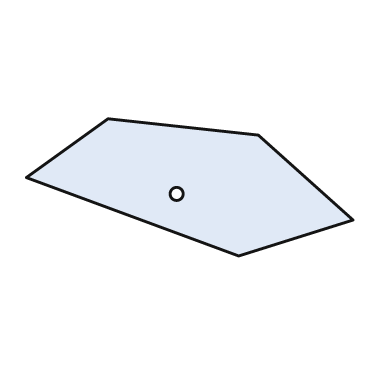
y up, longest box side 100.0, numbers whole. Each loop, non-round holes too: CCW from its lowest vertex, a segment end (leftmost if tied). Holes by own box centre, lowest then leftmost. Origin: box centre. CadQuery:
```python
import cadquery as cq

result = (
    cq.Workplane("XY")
    .moveTo(15.0, -21.0)
    .lineTo(50.0, -10.0)
    .lineTo(21.0, 16.0)
    .lineTo(-25.0, 21.0)
    .lineTo(-50.0, 3.0)
    .close()
    .moveTo(-4.0, -2.0)
    .circle(2.0)
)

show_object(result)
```